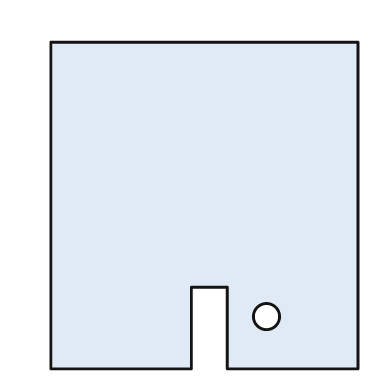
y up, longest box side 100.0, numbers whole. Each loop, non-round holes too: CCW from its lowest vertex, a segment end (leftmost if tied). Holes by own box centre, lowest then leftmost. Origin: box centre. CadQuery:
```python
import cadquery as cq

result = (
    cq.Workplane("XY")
    .moveTo(-47.0, -50.0)
    .lineTo(-4.0, -50.0)
    .lineTo(-4.0, -25.0)
    .lineTo(7.0, -25.0)
    .lineTo(7.0, -50.0)
    .lineTo(47.0, -50.0)
    .lineTo(47.0, 50.0)
    .lineTo(-47.0, 50.0)
    .close()
    .moveTo(19.0, -34.0)
    .circle(4.0)
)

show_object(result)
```